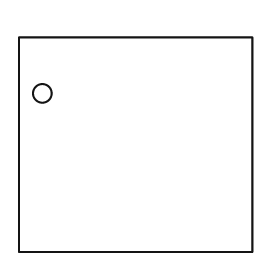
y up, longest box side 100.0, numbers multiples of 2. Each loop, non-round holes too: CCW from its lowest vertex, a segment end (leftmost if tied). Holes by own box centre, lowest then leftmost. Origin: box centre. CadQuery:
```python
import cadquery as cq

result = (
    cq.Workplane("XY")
    .moveTo(-50.0, -46.0)
    .lineTo(50.0, -46.0)
    .lineTo(50.0, 46.0)
    .lineTo(-50.0, 46.0)
    .close()
    .moveTo(-40.0, 22.0)
    .circle(4.0)
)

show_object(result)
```